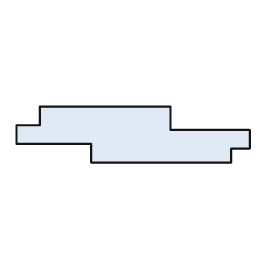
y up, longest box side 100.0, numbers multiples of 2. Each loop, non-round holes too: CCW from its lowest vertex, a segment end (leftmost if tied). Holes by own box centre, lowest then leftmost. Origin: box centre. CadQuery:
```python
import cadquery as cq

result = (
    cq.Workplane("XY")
    .moveTo(-18.0, -12.0)
    .lineTo(42.0, -12.0)
    .lineTo(42.0, -6.0)
    .lineTo(50.0, -6.0)
    .lineTo(50.0, 2.0)
    .lineTo(16.0, 2.0)
    .lineTo(16.0, 12.0)
    .lineTo(-40.0, 12.0)
    .lineTo(-40.0, 4.0)
    .lineTo(-50.0, 4.0)
    .lineTo(-50.0, -4.0)
    .lineTo(-18.0, -4.0)
    .close()
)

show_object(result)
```